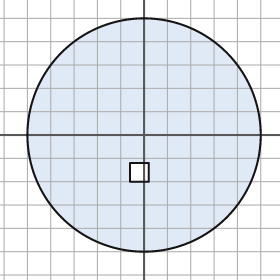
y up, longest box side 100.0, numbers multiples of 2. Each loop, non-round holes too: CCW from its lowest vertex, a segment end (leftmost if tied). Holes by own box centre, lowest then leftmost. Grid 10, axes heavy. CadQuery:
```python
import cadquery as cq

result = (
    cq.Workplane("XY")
    .moveTo(0.0, 0.0)
    .circle(50.0)
    .moveTo(-6.0, -20.0)
    .lineTo(2.0, -20.0)
    .lineTo(2.0, -12.0)
    .lineTo(-6.0, -12.0)
    .close()
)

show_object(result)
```